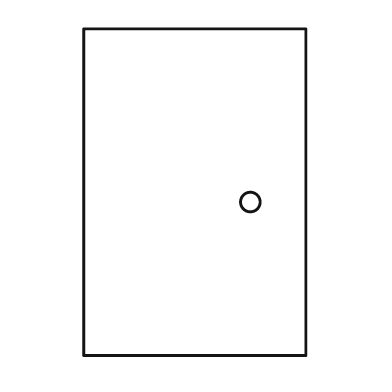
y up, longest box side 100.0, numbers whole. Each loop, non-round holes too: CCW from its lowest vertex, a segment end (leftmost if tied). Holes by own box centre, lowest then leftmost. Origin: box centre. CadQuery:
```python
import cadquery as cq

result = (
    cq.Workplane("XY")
    .moveTo(-34.0, -50.0)
    .lineTo(34.0, -50.0)
    .lineTo(34.0, 50.0)
    .lineTo(-34.0, 50.0)
    .close()
    .moveTo(17.0, -3.0)
    .circle(3.0)
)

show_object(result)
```